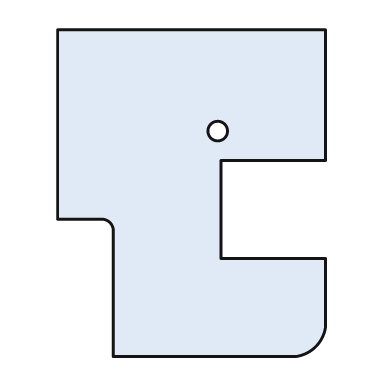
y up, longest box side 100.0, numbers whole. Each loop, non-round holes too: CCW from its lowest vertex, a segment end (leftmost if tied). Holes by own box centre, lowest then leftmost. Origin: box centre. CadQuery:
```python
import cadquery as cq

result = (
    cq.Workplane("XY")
    .moveTo(-24.0, -50.0)
    .lineTo(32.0, -50.0)
    .threePointArc((38.0, -47.0), (41.0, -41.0))
    .lineTo(41.0, -20.0)
    .lineTo(9.0, -20.0)
    .lineTo(9.0, 10.0)
    .lineTo(41.0, 10.0)
    .lineTo(41.0, 50.0)
    .lineTo(-41.0, 50.0)
    .lineTo(-41.0, -8.0)
    .lineTo(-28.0, -8.0)
    .threePointArc((-25.0, -9.0), (-24.0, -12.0))
    .close()
    .moveTo(8.0, 19.0)
    .circle(3.0)
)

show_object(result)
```